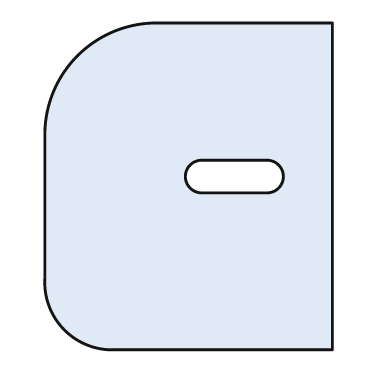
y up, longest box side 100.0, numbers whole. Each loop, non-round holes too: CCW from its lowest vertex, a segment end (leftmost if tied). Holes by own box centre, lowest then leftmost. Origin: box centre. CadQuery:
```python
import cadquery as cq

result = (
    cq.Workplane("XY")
    .moveTo(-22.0, -50.0)
    .lineTo(44.0, -50.0)
    .lineTo(44.0, 50.0)
    .lineTo(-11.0, 50.0)
    .threePointArc((-34.0, 40.0), (-44.0, 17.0))
    .lineTo(-44.0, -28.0)
    .threePointArc((-38.0, -44.0), (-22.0, -50.0))
    .close()
    .moveTo(4.0, -2.0)
    .lineTo(24.0, -2.0)
    .threePointArc((29.0, 3.0), (24.0, 8.0))
    .lineTo(4.0, 8.0)
    .threePointArc((-1.0, 3.0), (4.0, -2.0))
    .close()
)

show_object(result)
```